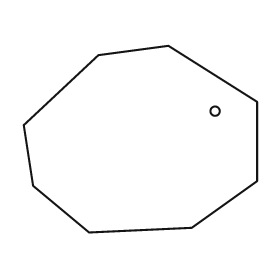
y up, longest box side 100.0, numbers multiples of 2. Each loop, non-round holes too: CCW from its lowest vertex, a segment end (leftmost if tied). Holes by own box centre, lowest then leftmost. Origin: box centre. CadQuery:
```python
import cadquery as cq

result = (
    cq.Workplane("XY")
    .moveTo(-22.0, -40.0)
    .lineTo(22.0, -38.0)
    .lineTo(50.0, -18.0)
    .lineTo(50.0, 16.0)
    .lineTo(12.0, 40.0)
    .lineTo(-18.0, 36.0)
    .lineTo(-50.0, 6.0)
    .lineTo(-46.0, -20.0)
    .close()
    .moveTo(32.0, 12.0)
    .circle(2.0)
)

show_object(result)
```